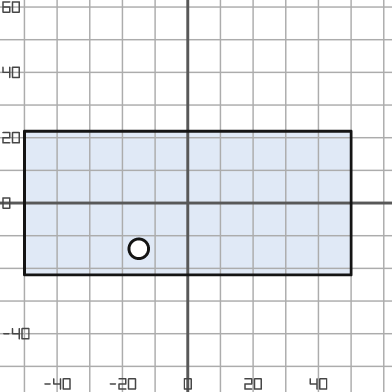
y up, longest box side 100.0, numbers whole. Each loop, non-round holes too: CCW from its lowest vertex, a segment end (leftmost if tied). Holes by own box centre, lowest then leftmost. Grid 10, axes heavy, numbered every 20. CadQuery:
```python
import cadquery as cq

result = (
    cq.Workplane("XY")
    .moveTo(-50.0, -22.0)
    .lineTo(50.0, -22.0)
    .lineTo(50.0, 22.0)
    .lineTo(-50.0, 22.0)
    .close()
    .moveTo(-15.0, -14.0)
    .circle(3.0)
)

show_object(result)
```